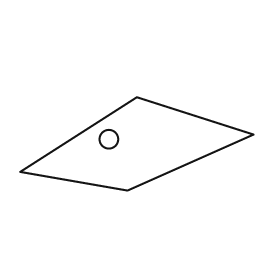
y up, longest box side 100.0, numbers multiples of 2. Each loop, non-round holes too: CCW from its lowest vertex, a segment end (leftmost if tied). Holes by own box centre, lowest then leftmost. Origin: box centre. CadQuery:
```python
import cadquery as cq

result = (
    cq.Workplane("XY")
    .moveTo(-4.0, -20.0)
    .lineTo(50.0, 4.0)
    .lineTo(0.0, 20.0)
    .lineTo(-50.0, -12.0)
    .close()
    .moveTo(-12.0, 2.0)
    .circle(4.0)
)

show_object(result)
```